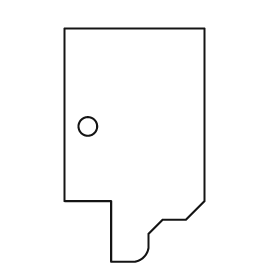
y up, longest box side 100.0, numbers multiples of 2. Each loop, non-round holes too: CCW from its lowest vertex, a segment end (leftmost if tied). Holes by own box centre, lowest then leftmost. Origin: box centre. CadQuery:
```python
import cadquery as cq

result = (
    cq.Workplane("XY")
    .moveTo(-10.0, -50.0)
    .lineTo(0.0, -50.0)
    .threePointArc((4.0, -48.0), (6.0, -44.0))
    .lineTo(6.0, -38.0)
    .lineTo(12.0, -32.0)
    .lineTo(22.0, -32.0)
    .lineTo(30.0, -24.0)
    .lineTo(30.0, 50.0)
    .lineTo(-30.0, 50.0)
    .lineTo(-30.0, -24.0)
    .lineTo(-10.0, -24.0)
    .close()
    .moveTo(-20.0, 8.0)
    .circle(4.0)
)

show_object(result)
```